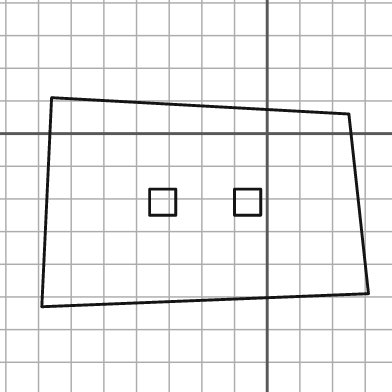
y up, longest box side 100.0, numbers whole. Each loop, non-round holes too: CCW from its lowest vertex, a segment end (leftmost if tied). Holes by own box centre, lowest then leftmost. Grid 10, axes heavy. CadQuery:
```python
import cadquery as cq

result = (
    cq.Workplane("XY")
    .moveTo(-69.0, -53.0)
    .lineTo(31.0, -49.0)
    .lineTo(25.0, 6.0)
    .lineTo(-66.0, 11.0)
    .close()
    .moveTo(-36.0, -25.0)
    .lineTo(-28.0, -25.0)
    .lineTo(-28.0, -17.0)
    .lineTo(-36.0, -17.0)
    .close()
    .moveTo(-10.0, -25.0)
    .lineTo(-2.0, -25.0)
    .lineTo(-2.0, -17.0)
    .lineTo(-10.0, -17.0)
    .close()
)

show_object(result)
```